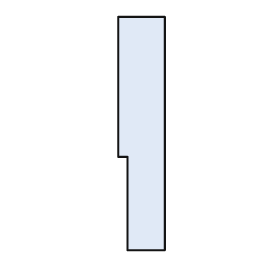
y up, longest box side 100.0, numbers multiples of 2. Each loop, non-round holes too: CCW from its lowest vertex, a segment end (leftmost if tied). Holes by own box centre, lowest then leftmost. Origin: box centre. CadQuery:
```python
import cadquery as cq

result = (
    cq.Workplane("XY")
    .moveTo(-6.0, -50.0)
    .lineTo(10.0, -50.0)
    .lineTo(10.0, 50.0)
    .lineTo(-10.0, 50.0)
    .lineTo(-10.0, -10.0)
    .lineTo(-6.0, -10.0)
    .close()
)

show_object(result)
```